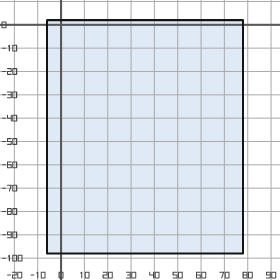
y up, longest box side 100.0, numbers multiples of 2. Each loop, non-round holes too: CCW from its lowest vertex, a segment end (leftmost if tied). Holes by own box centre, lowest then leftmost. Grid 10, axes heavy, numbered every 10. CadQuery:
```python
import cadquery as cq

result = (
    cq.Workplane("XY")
    .moveTo(-6.0, -98.0)
    .lineTo(78.0, -98.0)
    .lineTo(78.0, 2.0)
    .lineTo(-6.0, 2.0)
    .close()
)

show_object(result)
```